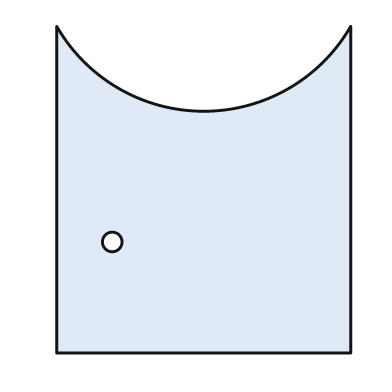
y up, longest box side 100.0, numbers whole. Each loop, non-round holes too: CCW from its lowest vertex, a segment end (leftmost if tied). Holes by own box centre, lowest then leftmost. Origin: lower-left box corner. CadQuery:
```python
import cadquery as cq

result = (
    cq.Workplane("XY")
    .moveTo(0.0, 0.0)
    .lineTo(90.0, 0.0)
    .lineTo(90.0, 100.0)
    .threePointArc((45.0, 74.0), (0.0, 100.0))
    .close()
    .moveTo(17.0, 34.0)
    .circle(3.0)
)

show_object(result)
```